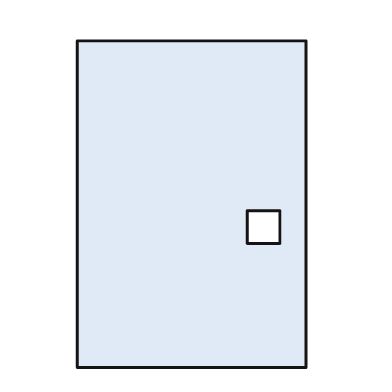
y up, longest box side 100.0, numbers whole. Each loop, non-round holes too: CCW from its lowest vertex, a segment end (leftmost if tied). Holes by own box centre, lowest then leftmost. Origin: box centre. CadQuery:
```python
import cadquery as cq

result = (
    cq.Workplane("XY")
    .moveTo(-35.0, -50.0)
    .lineTo(35.0, -50.0)
    .lineTo(35.0, 50.0)
    .lineTo(-35.0, 50.0)
    .close()
    .moveTo(17.0, -12.0)
    .lineTo(27.0, -12.0)
    .lineTo(27.0, -2.0)
    .lineTo(17.0, -2.0)
    .close()
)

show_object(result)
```